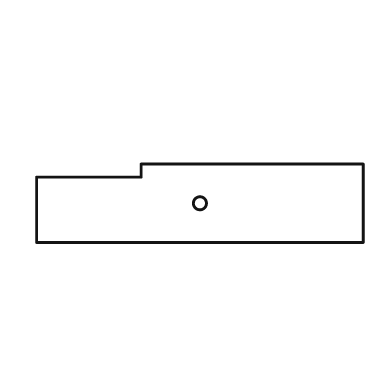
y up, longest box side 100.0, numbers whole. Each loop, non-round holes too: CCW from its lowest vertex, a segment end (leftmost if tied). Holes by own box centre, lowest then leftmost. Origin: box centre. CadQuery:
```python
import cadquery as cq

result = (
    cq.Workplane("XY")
    .moveTo(-50.0, -12.0)
    .lineTo(50.0, -12.0)
    .lineTo(50.0, 12.0)
    .lineTo(-18.0, 12.0)
    .lineTo(-18.0, 8.0)
    .lineTo(-50.0, 8.0)
    .close()
    .moveTo(0.0, 0.0)
    .circle(2.0)
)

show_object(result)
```